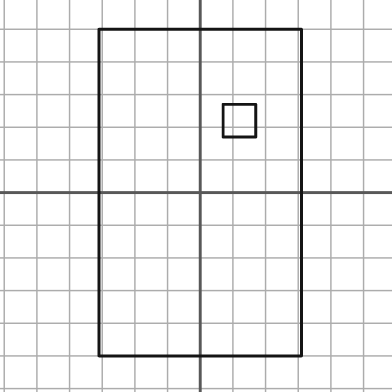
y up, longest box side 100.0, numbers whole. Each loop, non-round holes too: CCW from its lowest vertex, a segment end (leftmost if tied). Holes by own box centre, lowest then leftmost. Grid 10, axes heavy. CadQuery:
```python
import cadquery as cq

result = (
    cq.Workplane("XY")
    .moveTo(-31.0, -50.0)
    .lineTo(31.0, -50.0)
    .lineTo(31.0, 50.0)
    .lineTo(-31.0, 50.0)
    .close()
    .moveTo(7.0, 17.0)
    .lineTo(17.0, 17.0)
    .lineTo(17.0, 27.0)
    .lineTo(7.0, 27.0)
    .close()
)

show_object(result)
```